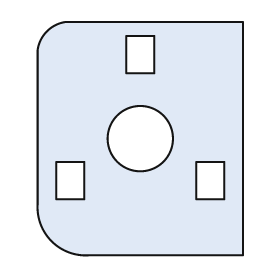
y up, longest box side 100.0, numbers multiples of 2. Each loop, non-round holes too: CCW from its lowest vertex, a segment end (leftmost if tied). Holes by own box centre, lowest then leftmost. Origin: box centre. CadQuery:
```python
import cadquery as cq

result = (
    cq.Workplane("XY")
    .moveTo(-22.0, -50.0)
    .lineTo(44.0, -50.0)
    .lineTo(44.0, 50.0)
    .lineTo(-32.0, 50.0)
    .threePointArc((-40.0, 46.0), (-44.0, 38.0))
    .lineTo(-44.0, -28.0)
    .threePointArc((-38.0, -44.0), (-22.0, -50.0))
    .close()
    .moveTo(-36.0, -26.0)
    .lineTo(-24.0, -26.0)
    .lineTo(-24.0, -10.0)
    .lineTo(-36.0, -10.0)
    .close()
    .moveTo(24.0, -26.0)
    .lineTo(36.0, -26.0)
    .lineTo(36.0, -10.0)
    .lineTo(24.0, -10.0)
    .close()
    .moveTo(0.0, 0.0)
    .circle(14.0)
    .moveTo(-6.0, 28.0)
    .lineTo(6.0, 28.0)
    .lineTo(6.0, 44.0)
    .lineTo(-6.0, 44.0)
    .close()
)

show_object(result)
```